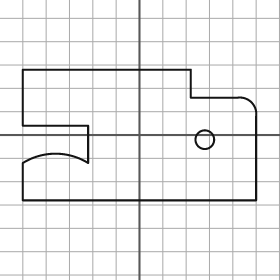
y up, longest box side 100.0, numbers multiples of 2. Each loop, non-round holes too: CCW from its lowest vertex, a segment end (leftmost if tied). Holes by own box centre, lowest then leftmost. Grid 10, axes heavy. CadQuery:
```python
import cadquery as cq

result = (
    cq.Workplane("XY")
    .moveTo(-50.0, -28.0)
    .lineTo(50.0, -28.0)
    .lineTo(50.0, 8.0)
    .threePointArc((48.0, 14.0), (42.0, 16.0))
    .lineTo(22.0, 16.0)
    .lineTo(22.0, 28.0)
    .lineTo(-50.0, 28.0)
    .lineTo(-50.0, 4.0)
    .lineTo(-22.0, 4.0)
    .lineTo(-22.0, -12.0)
    .threePointArc((-36.0, -8.0), (-50.0, -12.0))
    .close()
    .moveTo(28.0, -2.0)
    .circle(4.0)
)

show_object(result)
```